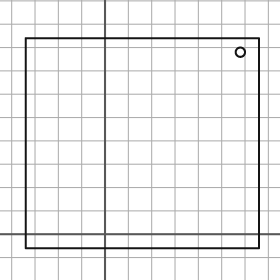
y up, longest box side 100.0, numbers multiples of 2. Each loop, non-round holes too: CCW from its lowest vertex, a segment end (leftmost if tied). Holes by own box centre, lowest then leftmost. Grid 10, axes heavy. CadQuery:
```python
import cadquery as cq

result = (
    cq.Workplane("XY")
    .moveTo(-34.0, -6.0)
    .lineTo(66.0, -6.0)
    .lineTo(66.0, 84.0)
    .lineTo(-34.0, 84.0)
    .close()
    .moveTo(58.0, 78.0)
    .circle(2.0)
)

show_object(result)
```